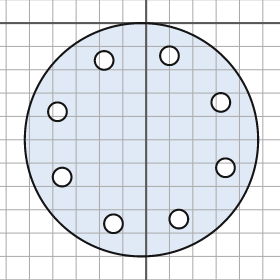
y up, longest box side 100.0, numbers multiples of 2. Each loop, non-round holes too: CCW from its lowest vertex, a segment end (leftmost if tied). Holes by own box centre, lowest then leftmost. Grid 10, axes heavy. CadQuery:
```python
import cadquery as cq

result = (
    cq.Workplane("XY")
    .moveTo(-2.0, -50.0)
    .circle(50.0)
    .moveTo(-14.0, -86.0)
    .circle(4.0)
    .moveTo(14.0, -84.0)
    .circle(4.0)
    .moveTo(-36.0, -66.0)
    .circle(4.0)
    .moveTo(34.0, -62.0)
    .circle(4.0)
    .moveTo(-38.0, -38.0)
    .circle(4.0)
    .moveTo(32.0, -34.0)
    .circle(4.0)
    .moveTo(-18.0, -16.0)
    .circle(4.0)
    .moveTo(10.0, -14.0)
    .circle(4.0)
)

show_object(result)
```